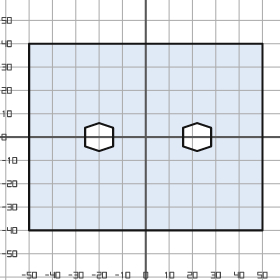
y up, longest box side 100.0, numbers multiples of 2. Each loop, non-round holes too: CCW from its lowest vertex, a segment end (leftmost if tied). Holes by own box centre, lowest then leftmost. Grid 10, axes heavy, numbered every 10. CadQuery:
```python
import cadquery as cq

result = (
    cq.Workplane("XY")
    .moveTo(-50.0, -40.0)
    .lineTo(50.0, -40.0)
    .lineTo(50.0, 40.0)
    .lineTo(-50.0, 40.0)
    .close()
    .moveTo(-20.0, -6.0)
    .lineTo(-14.0, -4.0)
    .lineTo(-14.0, 4.0)
    .lineTo(-20.0, 6.0)
    .lineTo(-26.0, 4.0)
    .lineTo(-26.0, -4.0)
    .close()
    .moveTo(22.0, -6.0)
    .lineTo(28.0, -4.0)
    .lineTo(28.0, 4.0)
    .lineTo(22.0, 6.0)
    .lineTo(16.0, 4.0)
    .lineTo(16.0, -4.0)
    .close()
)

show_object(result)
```